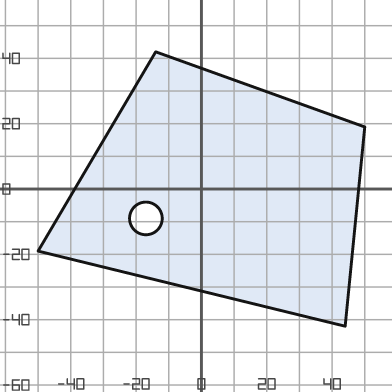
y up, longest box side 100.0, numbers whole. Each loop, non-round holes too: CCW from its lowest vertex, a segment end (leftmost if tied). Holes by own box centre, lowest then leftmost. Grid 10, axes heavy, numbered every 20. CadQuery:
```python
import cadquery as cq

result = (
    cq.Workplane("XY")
    .moveTo(44.0, -42.0)
    .lineTo(50.0, 19.0)
    .lineTo(-14.0, 42.0)
    .lineTo(-50.0, -19.0)
    .close()
    .moveTo(-17.0, -9.0)
    .circle(5.0)
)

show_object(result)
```